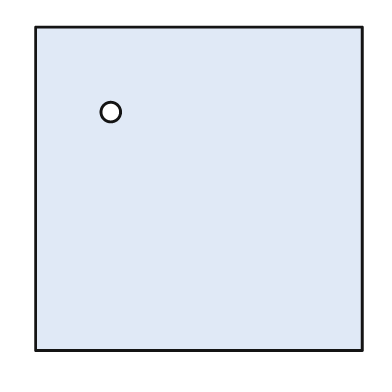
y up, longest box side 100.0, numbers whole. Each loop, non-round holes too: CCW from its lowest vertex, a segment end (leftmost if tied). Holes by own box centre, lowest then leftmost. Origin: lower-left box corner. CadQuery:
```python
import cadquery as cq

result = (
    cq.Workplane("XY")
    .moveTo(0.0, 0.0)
    .lineTo(100.0, 0.0)
    .lineTo(100.0, 99.0)
    .lineTo(0.0, 99.0)
    .close()
    .moveTo(23.0, 73.0)
    .circle(3.0)
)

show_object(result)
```